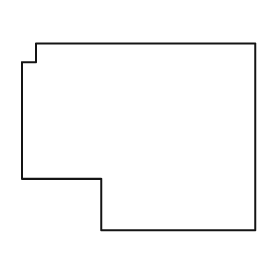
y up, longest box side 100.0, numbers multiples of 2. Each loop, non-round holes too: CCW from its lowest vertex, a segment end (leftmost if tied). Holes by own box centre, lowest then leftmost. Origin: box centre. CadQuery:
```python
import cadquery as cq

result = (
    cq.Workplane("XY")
    .moveTo(-16.0, -40.0)
    .lineTo(50.0, -40.0)
    .lineTo(50.0, 40.0)
    .lineTo(-44.0, 40.0)
    .lineTo(-44.0, 32.0)
    .lineTo(-50.0, 32.0)
    .lineTo(-50.0, -18.0)
    .lineTo(-16.0, -18.0)
    .close()
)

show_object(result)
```